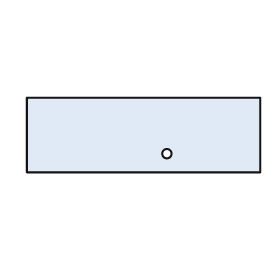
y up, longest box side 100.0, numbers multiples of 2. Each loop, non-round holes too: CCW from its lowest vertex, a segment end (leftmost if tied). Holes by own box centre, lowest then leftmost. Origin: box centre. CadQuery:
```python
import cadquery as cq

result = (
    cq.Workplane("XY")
    .moveTo(-50.0, -16.0)
    .lineTo(50.0, -16.0)
    .lineTo(50.0, 16.0)
    .lineTo(-50.0, 16.0)
    .close()
    .moveTo(10.0, -8.0)
    .circle(2.0)
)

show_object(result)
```